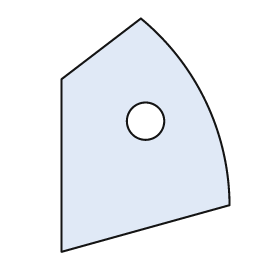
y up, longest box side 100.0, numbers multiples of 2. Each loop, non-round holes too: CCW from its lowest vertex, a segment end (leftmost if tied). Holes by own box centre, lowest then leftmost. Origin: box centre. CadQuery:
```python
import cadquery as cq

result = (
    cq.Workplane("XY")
    .moveTo(-36.0, -50.0)
    .lineTo(36.0, -30.0)
    .threePointArc((26.0, 14.0), (-2.0, 50.0))
    .lineTo(-36.0, 24.0)
    .close()
    .moveTo(0.0, 6.0)
    .circle(8.0)
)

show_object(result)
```